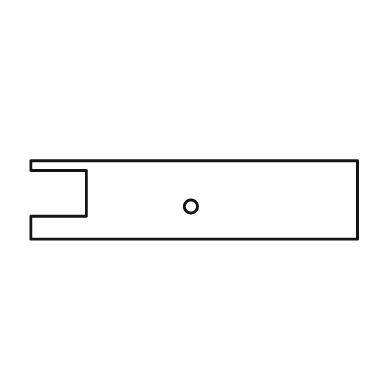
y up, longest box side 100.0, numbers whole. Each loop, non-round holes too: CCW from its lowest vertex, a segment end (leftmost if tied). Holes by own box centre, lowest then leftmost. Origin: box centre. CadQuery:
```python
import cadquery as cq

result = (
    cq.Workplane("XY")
    .moveTo(-50.0, -12.0)
    .lineTo(50.0, -12.0)
    .lineTo(50.0, 12.0)
    .lineTo(-50.0, 12.0)
    .lineTo(-50.0, 9.0)
    .lineTo(-33.0, 9.0)
    .lineTo(-33.0, -5.0)
    .lineTo(-50.0, -5.0)
    .close()
    .moveTo(-1.0, -2.0)
    .circle(2.0)
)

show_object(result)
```